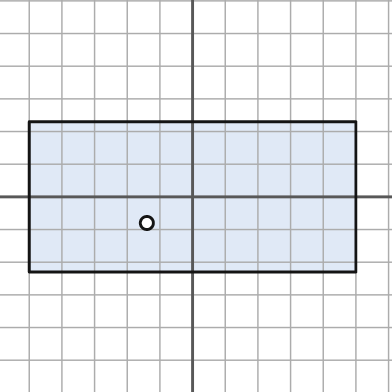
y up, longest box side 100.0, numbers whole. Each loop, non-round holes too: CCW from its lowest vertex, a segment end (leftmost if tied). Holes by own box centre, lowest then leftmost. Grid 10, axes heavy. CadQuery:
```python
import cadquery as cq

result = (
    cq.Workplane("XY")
    .moveTo(-50.0, -23.0)
    .lineTo(50.0, -23.0)
    .lineTo(50.0, 23.0)
    .lineTo(-50.0, 23.0)
    .close()
    .moveTo(-14.0, -8.0)
    .circle(2.0)
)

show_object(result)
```